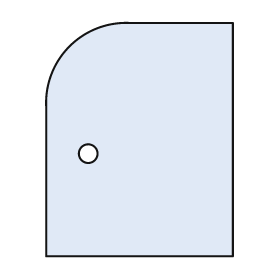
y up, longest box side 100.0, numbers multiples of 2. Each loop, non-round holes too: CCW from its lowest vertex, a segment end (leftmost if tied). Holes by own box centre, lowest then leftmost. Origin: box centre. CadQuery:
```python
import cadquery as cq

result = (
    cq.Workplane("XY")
    .moveTo(-40.0, -50.0)
    .lineTo(40.0, -50.0)
    .lineTo(40.0, 50.0)
    .lineTo(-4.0, 50.0)
    .threePointArc((-30.0, 40.0), (-40.0, 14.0))
    .close()
    .moveTo(-22.0, -6.0)
    .circle(4.0)
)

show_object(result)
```